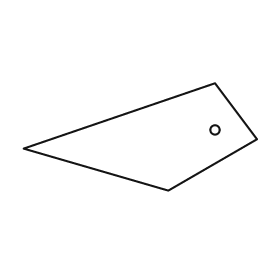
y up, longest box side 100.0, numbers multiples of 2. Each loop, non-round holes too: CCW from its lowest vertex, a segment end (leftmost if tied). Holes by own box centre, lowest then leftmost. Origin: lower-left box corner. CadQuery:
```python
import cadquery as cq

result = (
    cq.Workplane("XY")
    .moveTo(62.0, 0.0)
    .lineTo(100.0, 22.0)
    .lineTo(82.0, 46.0)
    .lineTo(0.0, 18.0)
    .close()
    .moveTo(82.0, 26.0)
    .circle(2.0)
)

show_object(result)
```